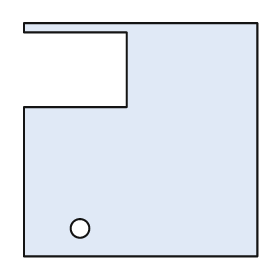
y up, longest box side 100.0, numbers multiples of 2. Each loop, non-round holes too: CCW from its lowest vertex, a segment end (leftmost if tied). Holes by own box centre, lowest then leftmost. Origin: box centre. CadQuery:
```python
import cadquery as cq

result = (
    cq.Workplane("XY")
    .moveTo(-50.0, -50.0)
    .lineTo(50.0, -50.0)
    .lineTo(50.0, 50.0)
    .lineTo(-50.0, 50.0)
    .lineTo(-50.0, 46.0)
    .lineTo(-6.0, 46.0)
    .lineTo(-6.0, 14.0)
    .lineTo(-50.0, 14.0)
    .close()
    .moveTo(-26.0, -38.0)
    .circle(4.0)
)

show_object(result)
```